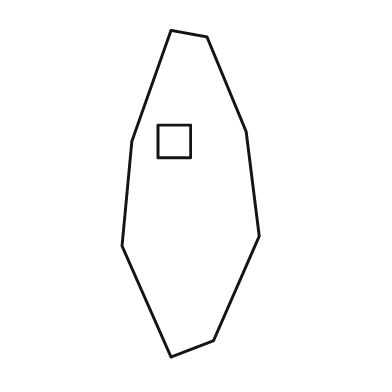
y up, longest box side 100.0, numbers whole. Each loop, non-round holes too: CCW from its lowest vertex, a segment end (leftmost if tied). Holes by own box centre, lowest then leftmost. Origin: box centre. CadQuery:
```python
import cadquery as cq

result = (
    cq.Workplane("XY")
    .moveTo(-6.0, -50.0)
    .lineTo(7.0, -45.0)
    .lineTo(21.0, -13.0)
    .lineTo(17.0, 19.0)
    .lineTo(5.0, 48.0)
    .lineTo(-6.0, 50.0)
    .lineTo(-18.0, 16.0)
    .lineTo(-21.0, -16.0)
    .close()
    .moveTo(-10.0, 11.0)
    .lineTo(0.0, 11.0)
    .lineTo(0.0, 21.0)
    .lineTo(-10.0, 21.0)
    .close()
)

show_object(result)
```